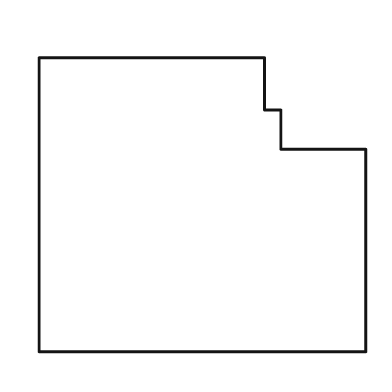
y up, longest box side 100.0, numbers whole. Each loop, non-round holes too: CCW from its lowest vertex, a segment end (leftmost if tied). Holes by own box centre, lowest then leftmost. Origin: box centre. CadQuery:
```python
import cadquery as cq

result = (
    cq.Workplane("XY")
    .moveTo(-50.0, -45.0)
    .lineTo(50.0, -45.0)
    .lineTo(50.0, 17.0)
    .lineTo(24.0, 17.0)
    .lineTo(24.0, 29.0)
    .lineTo(19.0, 29.0)
    .lineTo(19.0, 45.0)
    .lineTo(-50.0, 45.0)
    .close()
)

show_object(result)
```